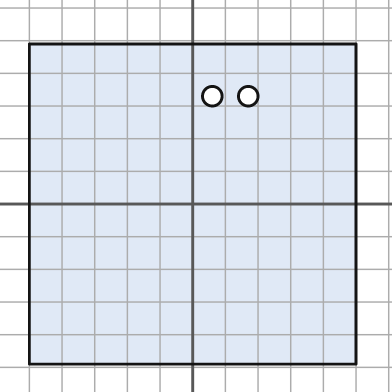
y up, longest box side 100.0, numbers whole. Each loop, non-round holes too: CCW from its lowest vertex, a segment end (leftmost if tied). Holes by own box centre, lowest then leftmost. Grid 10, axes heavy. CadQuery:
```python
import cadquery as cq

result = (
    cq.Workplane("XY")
    .moveTo(-50.0, -49.0)
    .lineTo(50.0, -49.0)
    .lineTo(50.0, 49.0)
    .lineTo(-50.0, 49.0)
    .close()
    .moveTo(6.0, 33.0)
    .circle(3.0)
    .moveTo(17.0, 33.0)
    .circle(3.0)
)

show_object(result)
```